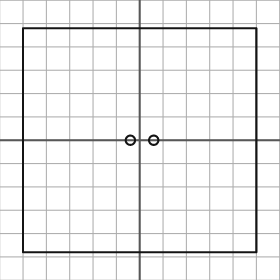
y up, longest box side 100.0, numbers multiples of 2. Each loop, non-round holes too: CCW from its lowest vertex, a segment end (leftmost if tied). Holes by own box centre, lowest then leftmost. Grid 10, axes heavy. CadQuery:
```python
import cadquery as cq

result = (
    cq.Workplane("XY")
    .moveTo(-50.0, -48.0)
    .lineTo(50.0, -48.0)
    .lineTo(50.0, 48.0)
    .lineTo(-50.0, 48.0)
    .close()
    .moveTo(-4.0, 0.0)
    .circle(2.0)
    .moveTo(6.0, 0.0)
    .circle(2.0)
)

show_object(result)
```